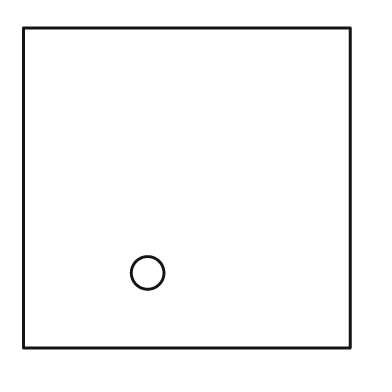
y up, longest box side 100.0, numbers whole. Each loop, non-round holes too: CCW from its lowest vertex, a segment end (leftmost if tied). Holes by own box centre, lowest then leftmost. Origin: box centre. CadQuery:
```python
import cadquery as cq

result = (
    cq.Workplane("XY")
    .moveTo(-50.0, -49.0)
    .lineTo(50.0, -49.0)
    .lineTo(50.0, 49.0)
    .lineTo(-50.0, 49.0)
    .close()
    .moveTo(-12.0, -26.0)
    .circle(5.0)
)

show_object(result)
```